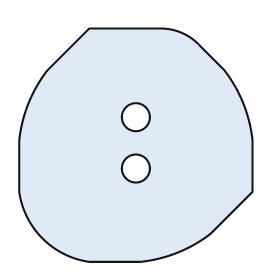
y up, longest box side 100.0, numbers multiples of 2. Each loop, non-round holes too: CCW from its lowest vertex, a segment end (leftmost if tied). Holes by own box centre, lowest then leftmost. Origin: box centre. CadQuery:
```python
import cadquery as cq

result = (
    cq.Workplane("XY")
    .moveTo(-20.0, -50.0)
    .lineTo(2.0, -50.0)
    .threePointArc((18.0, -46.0), (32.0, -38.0))
    .lineTo(50.0, -20.0)
    .lineTo(50.0, 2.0)
    .threePointArc((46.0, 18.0), (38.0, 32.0))
    .lineTo(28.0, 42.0)
    .threePointArc((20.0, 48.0), (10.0, 50.0))
    .lineTo(-20.0, 50.0)
    .lineTo(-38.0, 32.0)
    .threePointArc((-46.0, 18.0), (-50.0, 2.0))
    .lineTo(-50.0, -20.0)
    .threePointArc((-40.0, -40.0), (-20.0, -50.0))
    .close()
    .moveTo(0.0, -10.0)
    .circle(6.0)
    .moveTo(0.0, 12.0)
    .circle(6.0)
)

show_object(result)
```